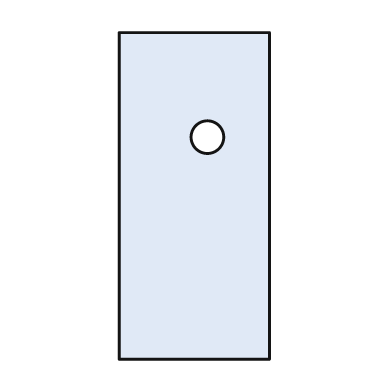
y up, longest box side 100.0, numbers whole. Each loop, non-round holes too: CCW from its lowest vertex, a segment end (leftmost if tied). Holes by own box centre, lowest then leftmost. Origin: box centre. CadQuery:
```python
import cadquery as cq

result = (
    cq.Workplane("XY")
    .moveTo(-23.0, -50.0)
    .lineTo(23.0, -50.0)
    .lineTo(23.0, 50.0)
    .lineTo(-23.0, 50.0)
    .close()
    .moveTo(4.0, 18.0)
    .circle(5.0)
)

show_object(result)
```